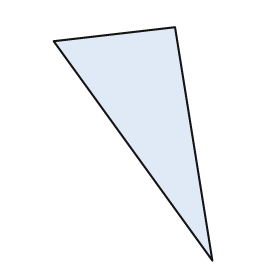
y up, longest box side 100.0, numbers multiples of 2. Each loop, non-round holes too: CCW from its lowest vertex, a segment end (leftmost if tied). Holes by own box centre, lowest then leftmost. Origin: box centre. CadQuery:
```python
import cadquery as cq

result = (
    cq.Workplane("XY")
    .moveTo(34.0, -50.0)
    .lineTo(18.0, 50.0)
    .lineTo(-34.0, 44.0)
    .close()
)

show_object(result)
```